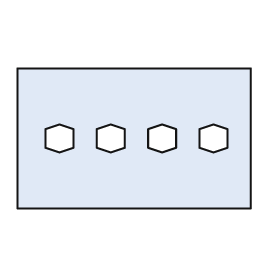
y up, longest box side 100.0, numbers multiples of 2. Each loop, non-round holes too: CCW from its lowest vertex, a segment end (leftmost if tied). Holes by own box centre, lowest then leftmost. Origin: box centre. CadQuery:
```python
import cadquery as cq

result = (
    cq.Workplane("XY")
    .moveTo(-50.0, -30.0)
    .lineTo(50.0, -30.0)
    .lineTo(50.0, 30.0)
    .lineTo(-50.0, 30.0)
    .close()
    .moveTo(-32.0, -6.0)
    .lineTo(-26.0, -4.0)
    .lineTo(-26.0, 4.0)
    .lineTo(-32.0, 6.0)
    .lineTo(-38.0, 4.0)
    .lineTo(-38.0, -4.0)
    .close()
    .moveTo(-10.0, -6.0)
    .lineTo(-4.0, -4.0)
    .lineTo(-4.0, 4.0)
    .lineTo(-10.0, 6.0)
    .lineTo(-16.0, 4.0)
    .lineTo(-16.0, -4.0)
    .close()
    .moveTo(12.0, -6.0)
    .lineTo(18.0, -4.0)
    .lineTo(18.0, 4.0)
    .lineTo(12.0, 6.0)
    .lineTo(6.0, 4.0)
    .lineTo(6.0, -4.0)
    .close()
    .moveTo(34.0, -6.0)
    .lineTo(40.0, -4.0)
    .lineTo(40.0, 4.0)
    .lineTo(34.0, 6.0)
    .lineTo(28.0, 4.0)
    .lineTo(28.0, -4.0)
    .close()
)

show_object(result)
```